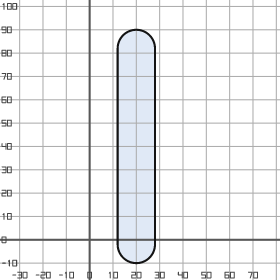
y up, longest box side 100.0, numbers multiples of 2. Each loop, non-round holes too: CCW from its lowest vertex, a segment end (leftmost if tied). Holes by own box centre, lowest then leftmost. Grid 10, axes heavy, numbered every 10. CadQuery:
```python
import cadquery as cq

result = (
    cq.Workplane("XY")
    .moveTo(12.0, -2.0)
    .threePointArc((20.0, -10.0), (28.0, -2.0))
    .lineTo(28.0, 82.0)
    .threePointArc((20.0, 90.0), (12.0, 82.0))
    .close()
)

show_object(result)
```